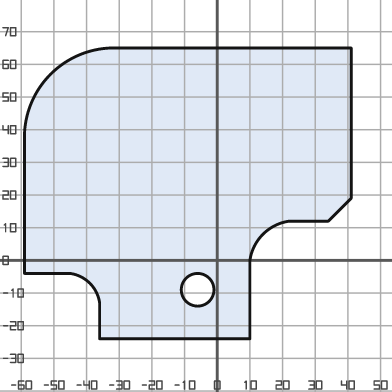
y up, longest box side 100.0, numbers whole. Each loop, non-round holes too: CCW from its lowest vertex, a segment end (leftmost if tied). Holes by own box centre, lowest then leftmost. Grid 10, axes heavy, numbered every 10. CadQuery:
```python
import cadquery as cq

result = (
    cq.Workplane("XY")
    .moveTo(-36.0, -24.0)
    .lineTo(10.0, -24.0)
    .lineTo(10.0, 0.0)
    .threePointArc((14.0, 8.0), (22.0, 12.0))
    .lineTo(34.0, 12.0)
    .lineTo(41.0, 19.0)
    .lineTo(41.0, 65.0)
    .lineTo(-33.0, 65.0)
    .threePointArc((-51.0, 57.0), (-59.0, 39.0))
    .lineTo(-59.0, -4.0)
    .lineTo(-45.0, -4.0)
    .threePointArc((-39.0, -7.0), (-36.0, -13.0))
    .close()
    .moveTo(-6.0, -9.0)
    .circle(5.0)
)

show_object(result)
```